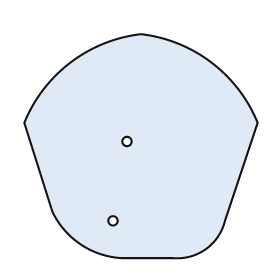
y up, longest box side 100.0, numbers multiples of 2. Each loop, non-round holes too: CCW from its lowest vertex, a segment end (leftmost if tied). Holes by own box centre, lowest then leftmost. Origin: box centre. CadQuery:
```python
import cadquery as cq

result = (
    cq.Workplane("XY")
    .moveTo(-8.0, -48.0)
    .lineTo(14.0, -48.0)
    .threePointArc((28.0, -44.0), (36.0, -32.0))
    .lineTo(50.0, 10.0)
    .threePointArc((30.0, 36.0), (0.0, 48.0))
    .threePointArc((-30.0, 36.0), (-50.0, 10.0))
    .lineTo(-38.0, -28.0)
    .threePointArc((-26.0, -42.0), (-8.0, -48.0))
    .close()
    .moveTo(-12.0, -32.0)
    .circle(2.0)
    .moveTo(-6.0, 2.0)
    .circle(2.0)
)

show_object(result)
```